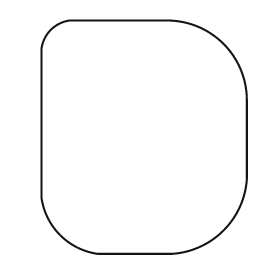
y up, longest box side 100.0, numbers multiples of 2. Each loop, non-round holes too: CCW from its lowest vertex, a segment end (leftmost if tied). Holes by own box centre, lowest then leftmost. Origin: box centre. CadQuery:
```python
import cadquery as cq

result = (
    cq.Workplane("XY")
    .moveTo(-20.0, -50.0)
    .lineTo(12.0, -50.0)
    .threePointArc((34.0, -40.0), (44.0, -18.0))
    .lineTo(44.0, 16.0)
    .threePointArc((34.0, 40.0), (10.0, 50.0))
    .lineTo(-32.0, 50.0)
    .threePointArc((-40.0, 46.0), (-44.0, 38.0))
    .lineTo(-44.0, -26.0)
    .threePointArc((-36.0, -42.0), (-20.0, -50.0))
    .close()
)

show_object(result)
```